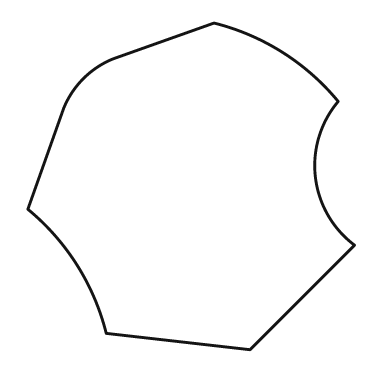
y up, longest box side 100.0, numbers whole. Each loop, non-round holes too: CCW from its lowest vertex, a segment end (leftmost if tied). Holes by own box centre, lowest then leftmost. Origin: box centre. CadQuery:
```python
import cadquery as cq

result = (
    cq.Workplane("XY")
    .moveTo(18.0, -50.0)
    .lineTo(50.0, -18.0)
    .threePointArc((38.0, 3.0), (45.0, 26.0))
    .threePointArc((28.0, 41.0), (7.0, 50.0))
    .lineTo(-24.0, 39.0)
    .threePointArc((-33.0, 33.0), (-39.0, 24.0))
    .lineTo(-50.0, -7.0)
    .threePointArc((-35.0, -24.0), (-26.0, -45.0))
    .close()
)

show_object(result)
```